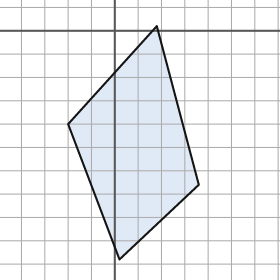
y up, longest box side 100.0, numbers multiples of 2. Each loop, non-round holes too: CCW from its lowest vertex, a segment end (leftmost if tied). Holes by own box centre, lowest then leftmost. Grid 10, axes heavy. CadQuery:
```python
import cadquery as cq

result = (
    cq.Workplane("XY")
    .moveTo(2.0, -98.0)
    .lineTo(36.0, -66.0)
    .lineTo(18.0, 2.0)
    .lineTo(-20.0, -40.0)
    .close()
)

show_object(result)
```